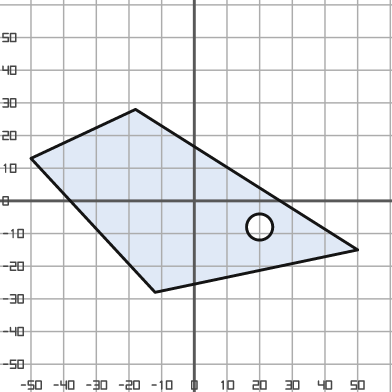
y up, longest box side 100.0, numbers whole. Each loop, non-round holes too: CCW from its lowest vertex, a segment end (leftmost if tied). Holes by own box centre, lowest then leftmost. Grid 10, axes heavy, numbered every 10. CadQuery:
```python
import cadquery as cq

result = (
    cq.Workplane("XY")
    .moveTo(-12.0, -28.0)
    .lineTo(50.0, -15.0)
    .lineTo(-18.0, 28.0)
    .lineTo(-50.0, 13.0)
    .close()
    .moveTo(20.0, -8.0)
    .circle(4.0)
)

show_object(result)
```